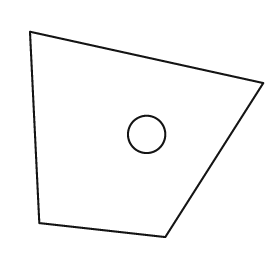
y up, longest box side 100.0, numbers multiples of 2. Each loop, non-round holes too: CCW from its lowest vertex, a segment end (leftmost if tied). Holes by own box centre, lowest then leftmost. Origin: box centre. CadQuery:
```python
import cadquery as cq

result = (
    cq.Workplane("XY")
    .moveTo(8.0, -44.0)
    .lineTo(50.0, 22.0)
    .lineTo(-50.0, 44.0)
    .lineTo(-46.0, -38.0)
    .close()
    .moveTo(0.0, 0.0)
    .circle(8.0)
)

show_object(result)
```